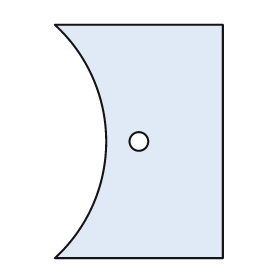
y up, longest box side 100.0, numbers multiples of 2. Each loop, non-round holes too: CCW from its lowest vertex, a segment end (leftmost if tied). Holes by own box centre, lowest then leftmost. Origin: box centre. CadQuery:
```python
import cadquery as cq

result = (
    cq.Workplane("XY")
    .moveTo(-36.0, -50.0)
    .lineTo(36.0, -50.0)
    .lineTo(36.0, 50.0)
    .lineTo(-36.0, 50.0)
    .threePointArc((-14.0, 0.0), (-36.0, -50.0))
    .close()
    .moveTo(0.0, 0.0)
    .circle(4.0)
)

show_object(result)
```